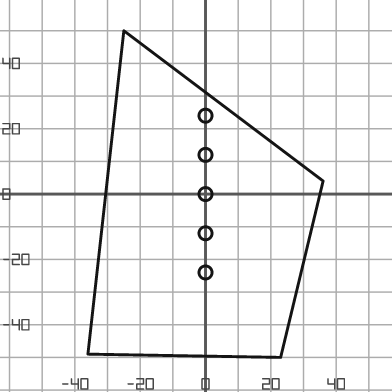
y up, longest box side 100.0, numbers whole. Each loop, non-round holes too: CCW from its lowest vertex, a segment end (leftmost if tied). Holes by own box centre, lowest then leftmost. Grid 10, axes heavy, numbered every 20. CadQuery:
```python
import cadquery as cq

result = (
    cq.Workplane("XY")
    .moveTo(23.0, -50.0)
    .lineTo(36.0, 4.0)
    .lineTo(-25.0, 50.0)
    .lineTo(-36.0, -49.0)
    .close()
    .moveTo(0.0, -24.0)
    .circle(2.0)
    .moveTo(0.0, -12.0)
    .circle(2.0)
    .moveTo(0.0, 0.0)
    .circle(2.0)
    .moveTo(0.0, 12.0)
    .circle(2.0)
    .moveTo(0.0, 24.0)
    .circle(2.0)
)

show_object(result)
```